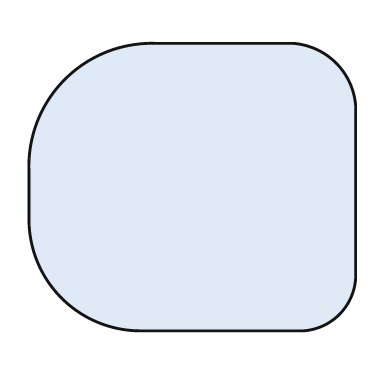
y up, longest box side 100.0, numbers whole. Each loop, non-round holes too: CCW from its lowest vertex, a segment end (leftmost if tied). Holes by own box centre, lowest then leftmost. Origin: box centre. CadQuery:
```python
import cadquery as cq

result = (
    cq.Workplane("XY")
    .moveTo(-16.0, -44.0)
    .lineTo(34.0, -44.0)
    .threePointArc((45.0, -39.0), (50.0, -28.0))
    .lineTo(50.0, 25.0)
    .threePointArc((44.0, 38.0), (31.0, 44.0))
    .lineTo(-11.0, 44.0)
    .threePointArc((-39.0, 33.0), (-50.0, 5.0))
    .lineTo(-50.0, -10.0)
    .threePointArc((-40.0, -34.0), (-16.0, -44.0))
    .close()
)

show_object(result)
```